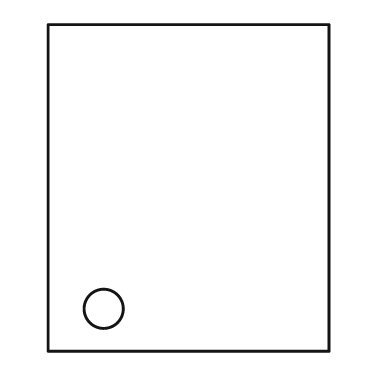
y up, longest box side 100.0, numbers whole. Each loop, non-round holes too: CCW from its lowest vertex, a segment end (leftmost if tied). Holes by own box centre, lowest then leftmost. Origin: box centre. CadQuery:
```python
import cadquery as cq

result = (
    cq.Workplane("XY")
    .moveTo(-43.0, -50.0)
    .lineTo(43.0, -50.0)
    .lineTo(43.0, 50.0)
    .lineTo(-43.0, 50.0)
    .close()
    .moveTo(-26.0, -37.0)
    .circle(6.0)
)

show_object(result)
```